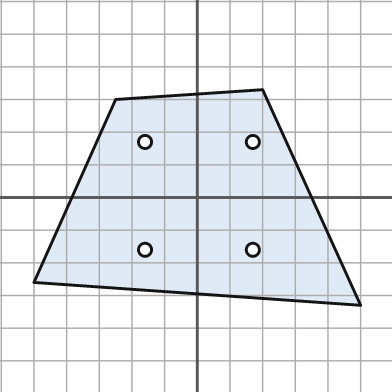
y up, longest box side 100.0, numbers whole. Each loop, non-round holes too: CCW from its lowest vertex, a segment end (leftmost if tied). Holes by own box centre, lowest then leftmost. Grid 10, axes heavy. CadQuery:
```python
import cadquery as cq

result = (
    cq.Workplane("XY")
    .moveTo(50.0, -33.0)
    .lineTo(20.0, 33.0)
    .lineTo(-25.0, 30.0)
    .lineTo(-50.0, -26.0)
    .close()
    .moveTo(-16.0, -16.0)
    .circle(2.0)
    .moveTo(17.0, -16.0)
    .circle(2.0)
    .moveTo(-16.0, 17.0)
    .circle(2.0)
    .moveTo(17.0, 17.0)
    .circle(2.0)
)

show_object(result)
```